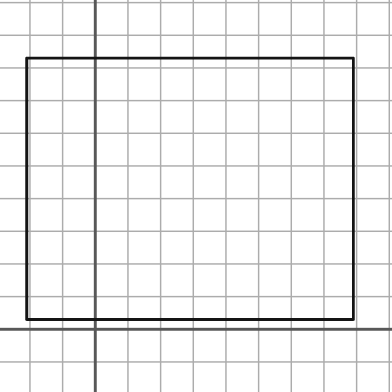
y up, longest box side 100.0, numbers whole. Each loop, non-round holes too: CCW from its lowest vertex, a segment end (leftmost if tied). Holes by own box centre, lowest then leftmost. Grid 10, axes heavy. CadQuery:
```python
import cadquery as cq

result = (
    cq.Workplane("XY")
    .moveTo(-21.0, 3.0)
    .lineTo(79.0, 3.0)
    .lineTo(79.0, 83.0)
    .lineTo(-21.0, 83.0)
    .close()
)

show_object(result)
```